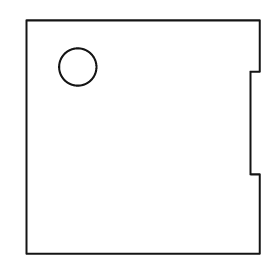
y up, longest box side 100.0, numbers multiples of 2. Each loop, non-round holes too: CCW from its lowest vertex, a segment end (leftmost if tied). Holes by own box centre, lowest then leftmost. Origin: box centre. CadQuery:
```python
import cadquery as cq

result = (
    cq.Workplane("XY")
    .moveTo(-50.0, -50.0)
    .lineTo(50.0, -50.0)
    .lineTo(50.0, -16.0)
    .lineTo(46.0, -16.0)
    .lineTo(46.0, 28.0)
    .lineTo(50.0, 28.0)
    .lineTo(50.0, 50.0)
    .lineTo(-50.0, 50.0)
    .close()
    .moveTo(-28.0, 30.0)
    .circle(8.0)
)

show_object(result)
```